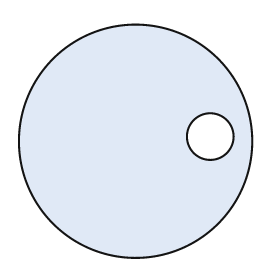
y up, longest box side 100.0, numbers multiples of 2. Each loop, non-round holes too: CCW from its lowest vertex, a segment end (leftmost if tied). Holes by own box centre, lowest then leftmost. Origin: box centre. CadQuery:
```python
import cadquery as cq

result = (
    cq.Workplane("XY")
    .moveTo(0.0, 0.0)
    .circle(50.0)
    .moveTo(32.0, 2.0)
    .circle(10.0)
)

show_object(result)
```